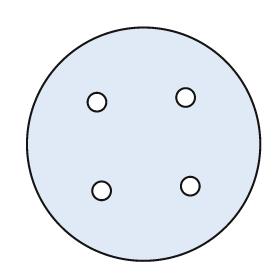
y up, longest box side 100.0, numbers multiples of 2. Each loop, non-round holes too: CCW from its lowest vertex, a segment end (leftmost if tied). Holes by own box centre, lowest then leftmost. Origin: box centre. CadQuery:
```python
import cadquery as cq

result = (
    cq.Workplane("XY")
    .moveTo(0.0, 0.0)
    .circle(50.0)
    .moveTo(-18.0, -20.0)
    .circle(4.0)
    .moveTo(20.0, -18.0)
    .circle(4.0)
    .moveTo(-20.0, 18.0)
    .circle(4.0)
    .moveTo(18.0, 20.0)
    .circle(4.0)
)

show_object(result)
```